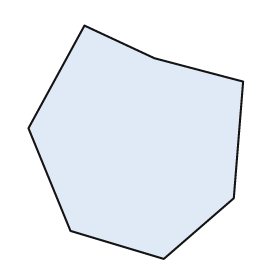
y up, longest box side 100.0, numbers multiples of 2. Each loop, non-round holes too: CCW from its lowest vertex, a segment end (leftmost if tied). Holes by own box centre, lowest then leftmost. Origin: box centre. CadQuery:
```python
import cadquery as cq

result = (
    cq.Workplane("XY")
    .moveTo(12.0, -50.0)
    .lineTo(42.0, -24.0)
    .lineTo(46.0, 26.0)
    .lineTo(8.0, 36.0)
    .lineTo(-22.0, 50.0)
    .lineTo(-46.0, 6.0)
    .lineTo(-28.0, -38.0)
    .close()
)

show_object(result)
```